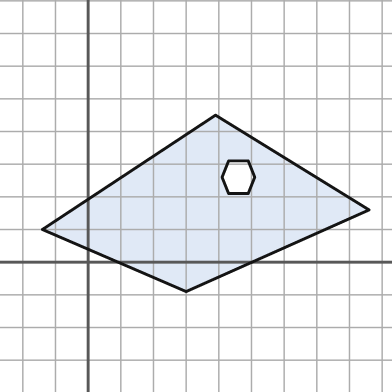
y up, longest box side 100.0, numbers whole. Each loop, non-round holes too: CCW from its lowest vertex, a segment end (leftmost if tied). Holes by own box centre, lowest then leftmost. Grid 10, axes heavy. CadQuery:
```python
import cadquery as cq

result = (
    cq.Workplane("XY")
    .moveTo(30.0, -9.0)
    .lineTo(86.0, 16.0)
    .lineTo(39.0, 45.0)
    .lineTo(-14.0, 10.0)
    .close()
    .moveTo(43.0, 21.0)
    .lineTo(49.0, 21.0)
    .lineTo(51.0, 26.0)
    .lineTo(49.0, 31.0)
    .lineTo(43.0, 31.0)
    .lineTo(41.0, 26.0)
    .close()
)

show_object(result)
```